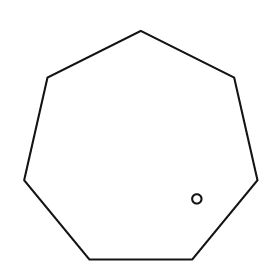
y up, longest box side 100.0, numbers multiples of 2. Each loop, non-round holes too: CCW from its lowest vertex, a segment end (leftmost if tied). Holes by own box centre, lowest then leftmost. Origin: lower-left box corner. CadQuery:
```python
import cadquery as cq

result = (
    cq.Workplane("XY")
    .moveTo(28.0, 0.0)
    .lineTo(72.0, 0.0)
    .lineTo(100.0, 34.0)
    .lineTo(90.0, 78.0)
    .lineTo(50.0, 98.0)
    .lineTo(10.0, 78.0)
    .lineTo(0.0, 34.0)
    .close()
    .moveTo(74.0, 26.0)
    .circle(2.0)
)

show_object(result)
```